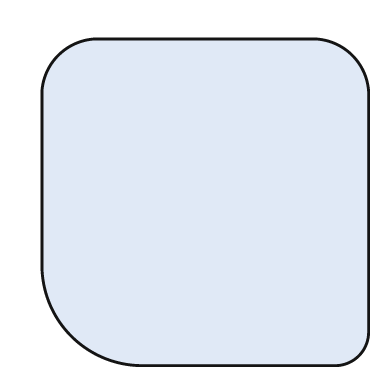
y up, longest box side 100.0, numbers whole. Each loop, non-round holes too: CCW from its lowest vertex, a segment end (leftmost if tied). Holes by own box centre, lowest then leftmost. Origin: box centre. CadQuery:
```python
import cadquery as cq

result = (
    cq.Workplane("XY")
    .moveTo(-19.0, -50.0)
    .lineTo(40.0, -50.0)
    .threePointArc((47.0, -47.0), (50.0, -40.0))
    .lineTo(50.0, 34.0)
    .threePointArc((45.0, 45.0), (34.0, 50.0))
    .lineTo(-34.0, 50.0)
    .threePointArc((-45.0, 45.0), (-50.0, 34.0))
    .lineTo(-50.0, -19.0)
    .threePointArc((-41.0, -41.0), (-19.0, -50.0))
    .close()
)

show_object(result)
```